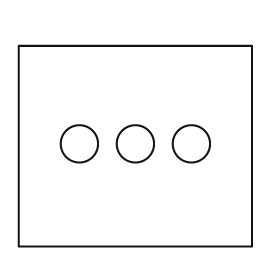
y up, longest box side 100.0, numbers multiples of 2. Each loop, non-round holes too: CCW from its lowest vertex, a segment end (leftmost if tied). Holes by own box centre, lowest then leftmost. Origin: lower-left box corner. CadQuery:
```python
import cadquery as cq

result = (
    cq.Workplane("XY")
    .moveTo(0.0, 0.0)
    .lineTo(100.0, 0.0)
    .lineTo(100.0, 86.0)
    .lineTo(0.0, 86.0)
    .close()
    .moveTo(26.0, 44.0)
    .circle(8.0)
    .moveTo(50.0, 44.0)
    .circle(8.0)
    .moveTo(74.0, 44.0)
    .circle(8.0)
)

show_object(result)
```